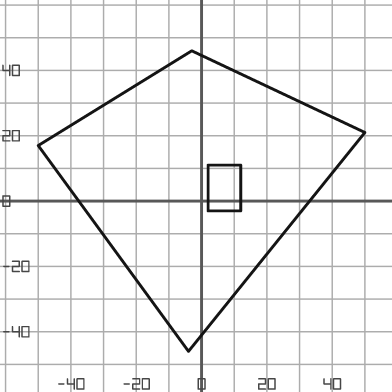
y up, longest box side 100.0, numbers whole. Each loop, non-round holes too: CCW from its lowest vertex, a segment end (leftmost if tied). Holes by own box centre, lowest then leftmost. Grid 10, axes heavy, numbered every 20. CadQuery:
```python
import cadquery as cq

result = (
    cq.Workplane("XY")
    .moveTo(-4.0, -46.0)
    .lineTo(50.0, 21.0)
    .lineTo(-3.0, 46.0)
    .lineTo(-50.0, 17.0)
    .close()
    .moveTo(2.0, -3.0)
    .lineTo(12.0, -3.0)
    .lineTo(12.0, 11.0)
    .lineTo(2.0, 11.0)
    .close()
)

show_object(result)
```